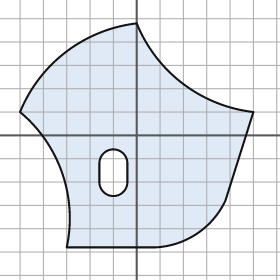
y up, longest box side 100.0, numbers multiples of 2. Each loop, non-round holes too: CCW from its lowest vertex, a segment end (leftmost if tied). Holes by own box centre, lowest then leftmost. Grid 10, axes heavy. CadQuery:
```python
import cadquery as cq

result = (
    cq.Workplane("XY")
    .moveTo(-30.0, -48.0)
    .lineTo(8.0, -48.0)
    .threePointArc((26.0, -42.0), (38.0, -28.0))
    .lineTo(50.0, 10.0)
    .threePointArc((20.0, 22.0), (0.0, 48.0))
    .threePointArc((-30.0, 36.0), (-50.0, 10.0))
    .threePointArc((-32.0, -16.0), (-30.0, -48.0))
    .close()
    .moveTo(-16.0, -20.0)
    .threePointArc((-10.0, -26.0), (-4.0, -20.0))
    .lineTo(-4.0, -12.0)
    .threePointArc((-10.0, -6.0), (-16.0, -12.0))
    .close()
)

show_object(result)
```